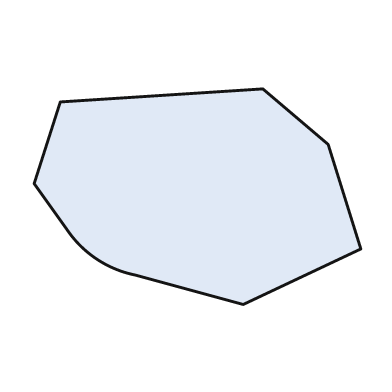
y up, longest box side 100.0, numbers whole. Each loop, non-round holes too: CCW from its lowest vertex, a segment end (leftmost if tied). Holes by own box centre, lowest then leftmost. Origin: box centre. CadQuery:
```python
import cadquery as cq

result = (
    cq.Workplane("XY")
    .moveTo(14.0, -33.0)
    .lineTo(50.0, -16.0)
    .lineTo(40.0, 16.0)
    .lineTo(20.0, 33.0)
    .lineTo(-42.0, 29.0)
    .lineTo(-50.0, 4.0)
    .lineTo(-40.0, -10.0)
    .threePointArc((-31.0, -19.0), (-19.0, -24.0))
    .close()
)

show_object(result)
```